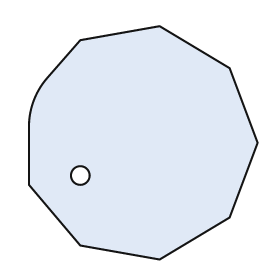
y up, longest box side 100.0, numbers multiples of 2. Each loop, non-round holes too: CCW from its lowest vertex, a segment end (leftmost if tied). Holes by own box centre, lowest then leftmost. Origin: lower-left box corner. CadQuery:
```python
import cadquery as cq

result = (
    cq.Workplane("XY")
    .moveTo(56.0, 0.0)
    .lineTo(86.0, 18.0)
    .lineTo(98.0, 50.0)
    .lineTo(86.0, 82.0)
    .lineTo(56.0, 100.0)
    .lineTo(22.0, 94.0)
    .lineTo(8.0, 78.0)
    .threePointArc((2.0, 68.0), (0.0, 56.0))
    .lineTo(0.0, 32.0)
    .lineTo(22.0, 6.0)
    .close()
    .moveTo(22.0, 36.0)
    .circle(4.0)
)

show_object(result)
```